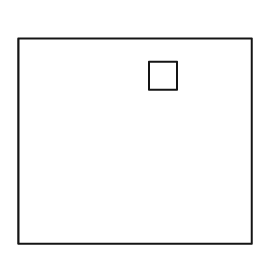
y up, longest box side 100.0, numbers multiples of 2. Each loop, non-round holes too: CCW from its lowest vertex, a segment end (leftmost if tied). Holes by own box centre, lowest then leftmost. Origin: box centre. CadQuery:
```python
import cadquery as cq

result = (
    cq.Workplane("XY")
    .moveTo(-50.0, -44.0)
    .lineTo(50.0, -44.0)
    .lineTo(50.0, 44.0)
    .lineTo(-50.0, 44.0)
    .close()
    .moveTo(6.0, 22.0)
    .lineTo(18.0, 22.0)
    .lineTo(18.0, 34.0)
    .lineTo(6.0, 34.0)
    .close()
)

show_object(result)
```